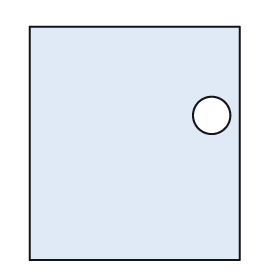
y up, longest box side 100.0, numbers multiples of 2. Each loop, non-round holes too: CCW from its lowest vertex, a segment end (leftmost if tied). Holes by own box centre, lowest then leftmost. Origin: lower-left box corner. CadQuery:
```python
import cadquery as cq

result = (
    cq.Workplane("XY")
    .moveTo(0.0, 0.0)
    .lineTo(90.0, 0.0)
    .lineTo(90.0, 100.0)
    .lineTo(0.0, 100.0)
    .close()
    .moveTo(78.0, 62.0)
    .circle(8.0)
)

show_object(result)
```